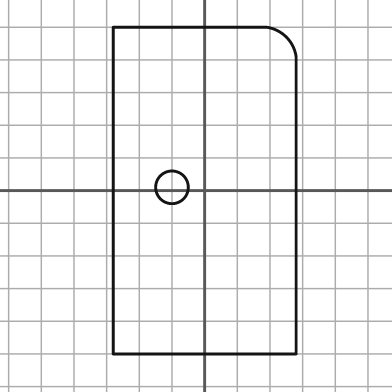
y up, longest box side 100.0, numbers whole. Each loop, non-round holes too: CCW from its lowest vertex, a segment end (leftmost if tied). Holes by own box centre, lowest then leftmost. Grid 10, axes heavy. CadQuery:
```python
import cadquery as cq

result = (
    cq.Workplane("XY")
    .moveTo(-28.0, -50.0)
    .lineTo(28.0, -50.0)
    .lineTo(28.0, 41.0)
    .threePointArc((25.0, 47.0), (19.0, 50.0))
    .lineTo(-28.0, 50.0)
    .close()
    .moveTo(-10.0, 1.0)
    .circle(5.0)
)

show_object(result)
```